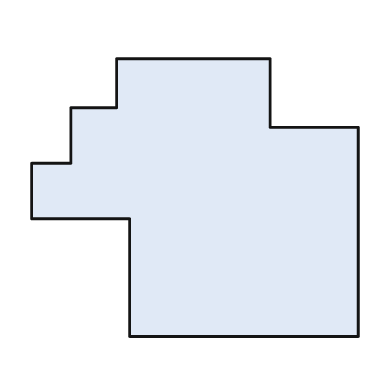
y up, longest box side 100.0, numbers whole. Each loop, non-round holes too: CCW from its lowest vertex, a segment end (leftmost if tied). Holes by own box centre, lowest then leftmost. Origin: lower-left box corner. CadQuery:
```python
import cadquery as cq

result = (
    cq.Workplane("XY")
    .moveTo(30.0, 0.0)
    .lineTo(100.0, 0.0)
    .lineTo(100.0, 64.0)
    .lineTo(73.0, 64.0)
    .lineTo(73.0, 85.0)
    .lineTo(26.0, 85.0)
    .lineTo(26.0, 70.0)
    .lineTo(12.0, 70.0)
    .lineTo(12.0, 53.0)
    .lineTo(0.0, 53.0)
    .lineTo(0.0, 36.0)
    .lineTo(30.0, 36.0)
    .close()
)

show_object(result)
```